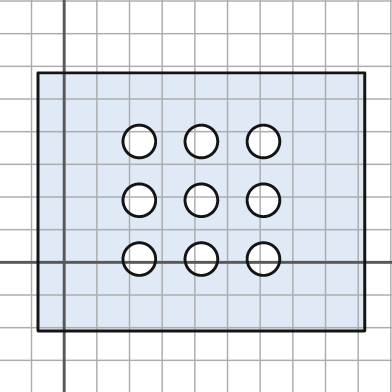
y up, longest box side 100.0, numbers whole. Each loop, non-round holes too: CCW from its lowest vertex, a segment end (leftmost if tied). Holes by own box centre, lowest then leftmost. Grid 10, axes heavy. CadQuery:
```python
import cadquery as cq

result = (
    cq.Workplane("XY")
    .moveTo(-8.0, -21.0)
    .lineTo(92.0, -21.0)
    .lineTo(92.0, 58.0)
    .lineTo(-8.0, 58.0)
    .close()
    .moveTo(23.0, 1.0)
    .circle(5.0)
    .moveTo(42.0, 1.0)
    .circle(5.0)
    .moveTo(61.0, 1.0)
    .circle(5.0)
    .moveTo(23.0, 19.0)
    .circle(5.0)
    .moveTo(42.0, 19.0)
    .circle(5.0)
    .moveTo(61.0, 19.0)
    .circle(5.0)
    .moveTo(23.0, 37.0)
    .circle(5.0)
    .moveTo(42.0, 37.0)
    .circle(5.0)
    .moveTo(61.0, 37.0)
    .circle(5.0)
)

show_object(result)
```